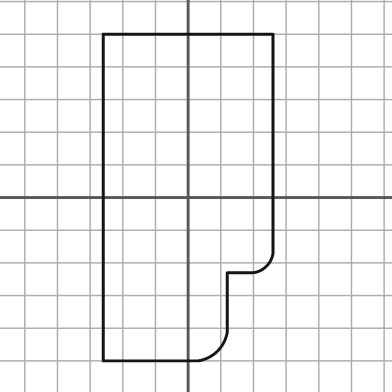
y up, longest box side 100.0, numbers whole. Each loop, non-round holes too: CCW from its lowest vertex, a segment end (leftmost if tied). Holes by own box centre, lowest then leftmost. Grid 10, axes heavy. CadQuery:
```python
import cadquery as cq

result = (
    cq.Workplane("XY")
    .moveTo(-26.0, -50.0)
    .lineTo(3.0, -50.0)
    .threePointArc((9.0, -47.0), (12.0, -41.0))
    .lineTo(12.0, -23.0)
    .lineTo(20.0, -23.0)
    .threePointArc((24.0, -21.0), (26.0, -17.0))
    .lineTo(26.0, 50.0)
    .lineTo(-26.0, 50.0)
    .close()
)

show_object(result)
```